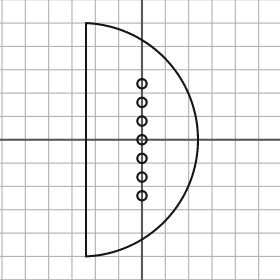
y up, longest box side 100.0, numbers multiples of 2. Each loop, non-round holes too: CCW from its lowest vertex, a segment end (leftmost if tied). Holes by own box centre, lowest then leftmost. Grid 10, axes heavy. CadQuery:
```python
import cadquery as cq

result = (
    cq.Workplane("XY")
    .moveTo(-24.0, -50.0)
    .threePointArc((24.0, 0.0), (-24.0, 50.0))
    .close()
    .moveTo(0.0, -24.0)
    .circle(2.0)
    .moveTo(0.0, -16.0)
    .circle(2.0)
    .moveTo(0.0, -8.0)
    .circle(2.0)
    .moveTo(0.0, 0.0)
    .circle(2.0)
    .moveTo(0.0, 8.0)
    .circle(2.0)
    .moveTo(0.0, 16.0)
    .circle(2.0)
    .moveTo(0.0, 24.0)
    .circle(2.0)
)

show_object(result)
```